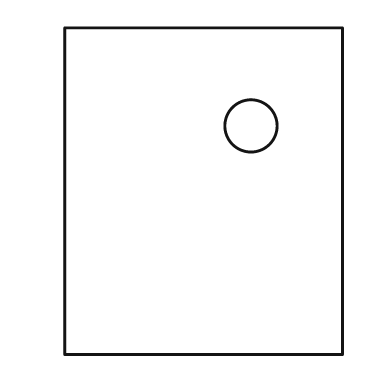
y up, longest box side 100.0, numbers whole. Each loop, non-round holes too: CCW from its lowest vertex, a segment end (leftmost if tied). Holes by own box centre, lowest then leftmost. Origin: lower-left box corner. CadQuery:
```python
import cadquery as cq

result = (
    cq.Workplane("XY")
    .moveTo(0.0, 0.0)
    .lineTo(85.0, 0.0)
    .lineTo(85.0, 100.0)
    .lineTo(0.0, 100.0)
    .close()
    .moveTo(57.0, 70.0)
    .circle(8.0)
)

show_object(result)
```